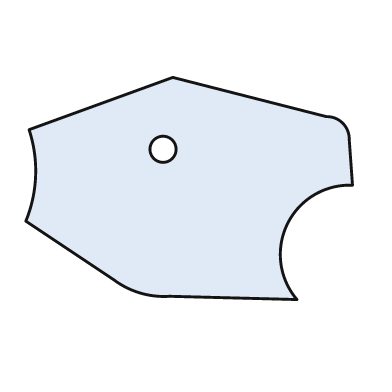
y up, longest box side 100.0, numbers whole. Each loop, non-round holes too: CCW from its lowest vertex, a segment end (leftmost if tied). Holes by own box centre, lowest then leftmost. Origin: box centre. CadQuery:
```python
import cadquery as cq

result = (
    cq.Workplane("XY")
    .moveTo(33.0, -34.0)
    .threePointArc((30.0, -11.0), (50.0, 1.0))
    .lineTo(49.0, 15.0)
    .threePointArc((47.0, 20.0), (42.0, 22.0))
    .lineTo(-5.0, 34.0)
    .lineTo(-49.0, 18.0)
    .threePointArc((-47.0, 4.0), (-50.0, -10.0))
    .lineTo(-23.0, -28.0)
    .threePointArc((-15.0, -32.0), (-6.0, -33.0))
    .close()
    .moveTo(-8.0, 12.0)
    .circle(4.0)
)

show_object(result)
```